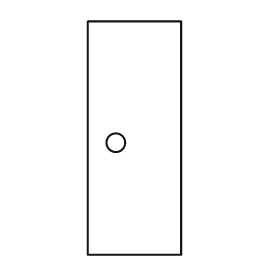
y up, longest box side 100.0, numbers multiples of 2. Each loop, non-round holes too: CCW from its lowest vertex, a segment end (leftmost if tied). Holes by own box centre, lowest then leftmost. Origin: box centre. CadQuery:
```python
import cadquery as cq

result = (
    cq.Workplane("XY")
    .moveTo(-20.0, -50.0)
    .lineTo(20.0, -50.0)
    .lineTo(20.0, 50.0)
    .lineTo(-20.0, 50.0)
    .close()
    .moveTo(-8.0, -2.0)
    .circle(4.0)
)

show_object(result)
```